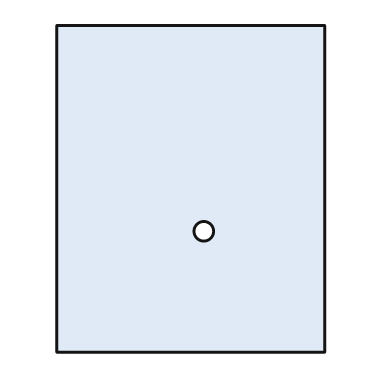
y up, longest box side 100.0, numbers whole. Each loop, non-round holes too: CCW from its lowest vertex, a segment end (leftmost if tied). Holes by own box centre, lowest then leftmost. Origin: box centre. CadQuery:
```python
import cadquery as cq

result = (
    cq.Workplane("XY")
    .moveTo(-41.0, -50.0)
    .lineTo(41.0, -50.0)
    .lineTo(41.0, 50.0)
    .lineTo(-41.0, 50.0)
    .close()
    .moveTo(4.0, -13.0)
    .circle(3.0)
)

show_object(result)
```